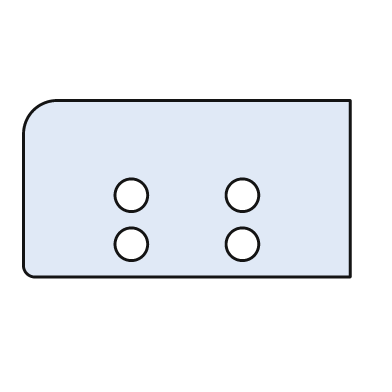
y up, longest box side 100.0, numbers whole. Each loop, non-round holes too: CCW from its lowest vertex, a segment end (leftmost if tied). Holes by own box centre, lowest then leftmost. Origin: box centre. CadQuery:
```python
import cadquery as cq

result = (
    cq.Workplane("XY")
    .moveTo(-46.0, -27.0)
    .lineTo(50.0, -27.0)
    .lineTo(50.0, 27.0)
    .lineTo(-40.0, 27.0)
    .threePointArc((-47.0, 24.0), (-50.0, 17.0))
    .lineTo(-50.0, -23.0)
    .threePointArc((-49.0, -26.0), (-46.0, -27.0))
    .close()
    .moveTo(-17.0, -17.0)
    .circle(5.0)
    .moveTo(17.0, -17.0)
    .circle(5.0)
    .moveTo(-17.0, -2.0)
    .circle(5.0)
    .moveTo(17.0, -2.0)
    .circle(5.0)
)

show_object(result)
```